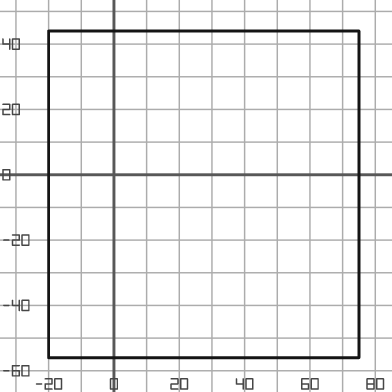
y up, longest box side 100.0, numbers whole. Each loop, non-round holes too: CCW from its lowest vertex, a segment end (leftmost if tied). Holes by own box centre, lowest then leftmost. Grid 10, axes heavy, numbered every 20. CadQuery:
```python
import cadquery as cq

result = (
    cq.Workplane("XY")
    .moveTo(-20.0, -56.0)
    .lineTo(75.0, -56.0)
    .lineTo(75.0, 44.0)
    .lineTo(-20.0, 44.0)
    .close()
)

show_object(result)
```